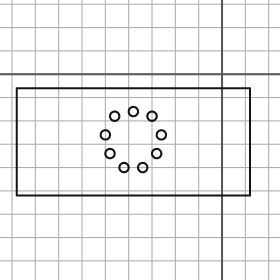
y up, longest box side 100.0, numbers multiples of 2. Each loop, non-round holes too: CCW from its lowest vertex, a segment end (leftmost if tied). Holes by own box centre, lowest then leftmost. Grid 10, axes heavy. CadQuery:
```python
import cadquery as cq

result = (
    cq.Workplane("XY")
    .moveTo(-88.0, -52.0)
    .lineTo(12.0, -52.0)
    .lineTo(12.0, -6.0)
    .lineTo(-88.0, -6.0)
    .close()
    .moveTo(-42.0, -40.0)
    .circle(2.0)
    .moveTo(-34.0, -40.0)
    .circle(2.0)
    .moveTo(-48.0, -34.0)
    .circle(2.0)
    .moveTo(-28.0, -34.0)
    .circle(2.0)
    .moveTo(-50.0, -26.0)
    .circle(2.0)
    .moveTo(-26.0, -26.0)
    .circle(2.0)
    .moveTo(-46.0, -18.0)
    .circle(2.0)
    .moveTo(-30.0, -18.0)
    .circle(2.0)
    .moveTo(-38.0, -16.0)
    .circle(2.0)
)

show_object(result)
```